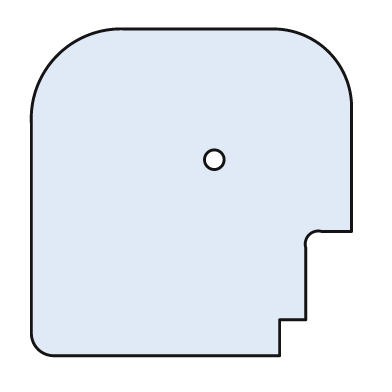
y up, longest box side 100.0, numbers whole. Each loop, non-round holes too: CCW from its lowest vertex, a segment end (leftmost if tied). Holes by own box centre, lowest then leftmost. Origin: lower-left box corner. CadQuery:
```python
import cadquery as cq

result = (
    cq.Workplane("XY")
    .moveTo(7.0, 0.0)
    .lineTo(76.0, 0.0)
    .lineTo(76.0, 11.0)
    .lineTo(84.0, 11.0)
    .lineTo(84.0, 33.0)
    .threePointArc((85.0, 37.0), (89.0, 38.0))
    .lineTo(98.0, 38.0)
    .lineTo(98.0, 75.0)
    .threePointArc((91.0, 93.0), (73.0, 100.0))
    .lineTo(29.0, 100.0)
    .threePointArc((8.0, 92.0), (0.0, 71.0))
    .lineTo(0.0, 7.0)
    .threePointArc((2.0, 2.0), (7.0, 0.0))
    .close()
    .moveTo(56.0, 60.0)
    .circle(3.0)
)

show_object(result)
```